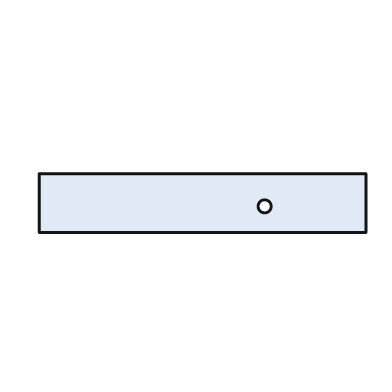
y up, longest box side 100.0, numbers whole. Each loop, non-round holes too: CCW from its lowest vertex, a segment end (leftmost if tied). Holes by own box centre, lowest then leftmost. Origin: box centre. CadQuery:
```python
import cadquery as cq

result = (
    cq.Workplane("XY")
    .moveTo(-50.0, -9.0)
    .lineTo(50.0, -9.0)
    .lineTo(50.0, 9.0)
    .lineTo(-50.0, 9.0)
    .close()
    .moveTo(19.0, -1.0)
    .circle(2.0)
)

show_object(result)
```